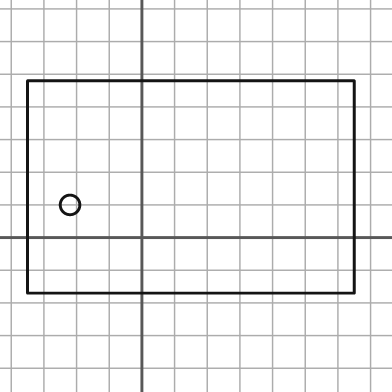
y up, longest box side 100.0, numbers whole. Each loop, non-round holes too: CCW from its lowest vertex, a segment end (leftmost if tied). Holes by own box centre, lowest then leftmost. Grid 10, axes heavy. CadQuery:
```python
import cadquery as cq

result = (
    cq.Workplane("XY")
    .moveTo(-35.0, -17.0)
    .lineTo(65.0, -17.0)
    .lineTo(65.0, 48.0)
    .lineTo(-35.0, 48.0)
    .close()
    .moveTo(-22.0, 10.0)
    .circle(3.0)
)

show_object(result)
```